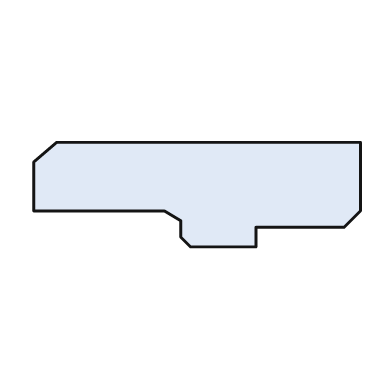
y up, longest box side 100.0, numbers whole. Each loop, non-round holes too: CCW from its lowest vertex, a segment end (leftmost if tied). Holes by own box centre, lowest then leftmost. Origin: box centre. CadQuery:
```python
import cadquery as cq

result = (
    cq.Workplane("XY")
    .moveTo(-2.0, -16.0)
    .lineTo(18.0, -16.0)
    .lineTo(18.0, -10.0)
    .lineTo(45.0, -10.0)
    .lineTo(50.0, -5.0)
    .lineTo(50.0, 16.0)
    .lineTo(-43.0, 16.0)
    .lineTo(-50.0, 10.0)
    .lineTo(-50.0, -5.0)
    .lineTo(-10.0, -5.0)
    .lineTo(-5.0, -8.0)
    .lineTo(-5.0, -13.0)
    .close()
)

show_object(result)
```